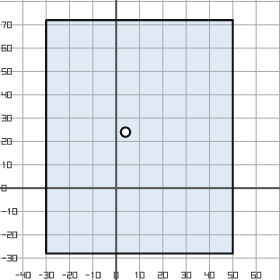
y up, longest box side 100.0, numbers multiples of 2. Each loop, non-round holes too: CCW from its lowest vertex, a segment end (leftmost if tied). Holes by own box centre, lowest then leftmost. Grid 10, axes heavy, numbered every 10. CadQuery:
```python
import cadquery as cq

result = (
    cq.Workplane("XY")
    .moveTo(-30.0, -28.0)
    .lineTo(50.0, -28.0)
    .lineTo(50.0, 72.0)
    .lineTo(-30.0, 72.0)
    .close()
    .moveTo(4.0, 24.0)
    .circle(2.0)
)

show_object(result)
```